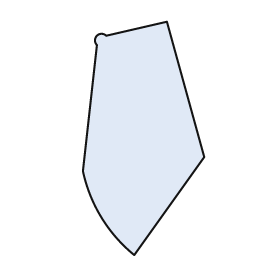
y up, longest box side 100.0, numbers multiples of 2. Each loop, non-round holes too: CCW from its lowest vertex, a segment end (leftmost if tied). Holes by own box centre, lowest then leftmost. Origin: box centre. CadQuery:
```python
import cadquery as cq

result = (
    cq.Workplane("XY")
    .moveTo(-4.0, -50.0)
    .lineTo(26.0, -8.0)
    .lineTo(10.0, 50.0)
    .lineTo(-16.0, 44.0)
    .threePointArc((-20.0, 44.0), (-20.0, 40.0))
    .lineTo(-26.0, -14.0)
    .threePointArc((-18.0, -34.0), (-4.0, -50.0))
    .close()
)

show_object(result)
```